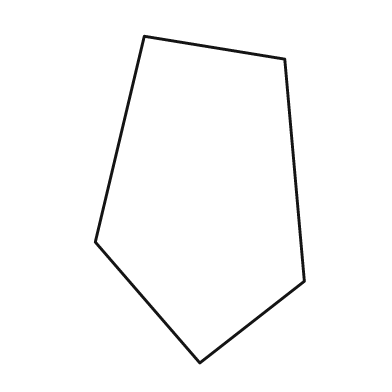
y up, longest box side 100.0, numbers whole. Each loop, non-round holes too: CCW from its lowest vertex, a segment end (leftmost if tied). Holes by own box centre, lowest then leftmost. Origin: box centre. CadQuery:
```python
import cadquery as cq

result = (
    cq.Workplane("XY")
    .moveTo(0.0, -50.0)
    .lineTo(32.0, -25.0)
    .lineTo(26.0, 43.0)
    .lineTo(-17.0, 50.0)
    .lineTo(-32.0, -13.0)
    .close()
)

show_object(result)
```